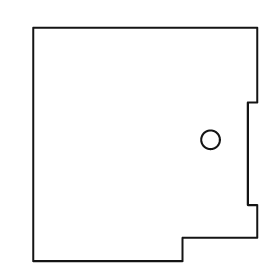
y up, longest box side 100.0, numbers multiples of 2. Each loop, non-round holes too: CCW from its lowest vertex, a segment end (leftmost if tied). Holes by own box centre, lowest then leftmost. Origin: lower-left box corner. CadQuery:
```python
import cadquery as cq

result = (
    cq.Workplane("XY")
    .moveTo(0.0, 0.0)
    .lineTo(64.0, 0.0)
    .lineTo(64.0, 10.0)
    .lineTo(96.0, 10.0)
    .lineTo(96.0, 24.0)
    .lineTo(92.0, 24.0)
    .lineTo(92.0, 68.0)
    .lineTo(96.0, 68.0)
    .lineTo(96.0, 100.0)
    .lineTo(0.0, 100.0)
    .close()
    .moveTo(76.0, 52.0)
    .circle(4.0)
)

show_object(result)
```